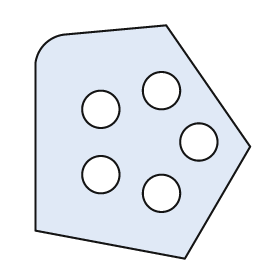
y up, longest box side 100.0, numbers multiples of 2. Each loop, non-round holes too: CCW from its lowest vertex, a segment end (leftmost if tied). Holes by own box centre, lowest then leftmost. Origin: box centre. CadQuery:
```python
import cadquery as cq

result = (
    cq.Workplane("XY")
    .moveTo(18.0, -50.0)
    .lineTo(46.0, -2.0)
    .lineTo(10.0, 50.0)
    .lineTo(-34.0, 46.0)
    .threePointArc((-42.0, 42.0), (-46.0, 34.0))
    .lineTo(-46.0, -38.0)
    .close()
    .moveTo(8.0, -22.0)
    .circle(8.0)
    .moveTo(-18.0, -14.0)
    .circle(8.0)
    .moveTo(24.0, 0.0)
    .circle(8.0)
    .moveTo(-18.0, 14.0)
    .circle(8.0)
    .moveTo(8.0, 22.0)
    .circle(8.0)
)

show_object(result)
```